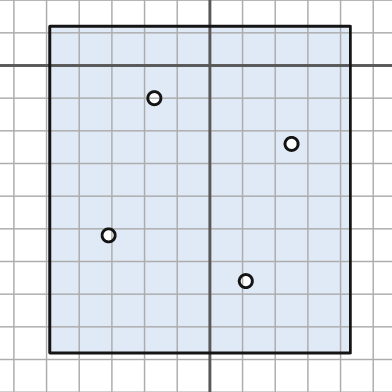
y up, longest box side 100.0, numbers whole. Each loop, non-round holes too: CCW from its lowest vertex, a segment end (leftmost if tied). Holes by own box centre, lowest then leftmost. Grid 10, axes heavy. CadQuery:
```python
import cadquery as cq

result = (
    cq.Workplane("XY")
    .moveTo(-49.0, -88.0)
    .lineTo(43.0, -88.0)
    .lineTo(43.0, 12.0)
    .lineTo(-49.0, 12.0)
    .close()
    .moveTo(11.0, -66.0)
    .circle(2.0)
    .moveTo(-31.0, -52.0)
    .circle(2.0)
    .moveTo(25.0, -24.0)
    .circle(2.0)
    .moveTo(-17.0, -10.0)
    .circle(2.0)
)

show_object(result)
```